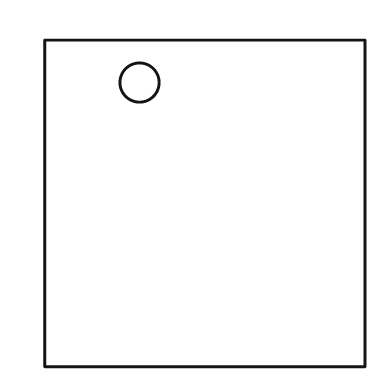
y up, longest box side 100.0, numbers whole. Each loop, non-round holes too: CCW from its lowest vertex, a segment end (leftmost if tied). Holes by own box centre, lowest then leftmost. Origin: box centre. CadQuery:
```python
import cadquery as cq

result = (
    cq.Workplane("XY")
    .moveTo(-49.0, -50.0)
    .lineTo(49.0, -50.0)
    .lineTo(49.0, 50.0)
    .lineTo(-49.0, 50.0)
    .close()
    .moveTo(-20.0, 37.0)
    .circle(6.0)
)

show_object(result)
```